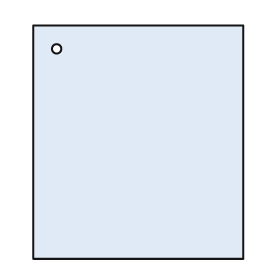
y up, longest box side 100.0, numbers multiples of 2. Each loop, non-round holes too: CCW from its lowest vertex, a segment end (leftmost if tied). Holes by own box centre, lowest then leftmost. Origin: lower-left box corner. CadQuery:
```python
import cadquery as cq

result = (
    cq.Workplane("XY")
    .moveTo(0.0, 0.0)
    .lineTo(90.0, 0.0)
    .lineTo(90.0, 100.0)
    .lineTo(0.0, 100.0)
    .close()
    .moveTo(10.0, 90.0)
    .circle(2.0)
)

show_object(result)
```